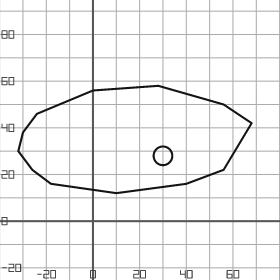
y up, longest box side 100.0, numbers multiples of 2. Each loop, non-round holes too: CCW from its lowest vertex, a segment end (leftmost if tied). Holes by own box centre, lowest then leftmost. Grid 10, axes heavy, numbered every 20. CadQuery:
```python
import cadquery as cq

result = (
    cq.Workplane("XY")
    .moveTo(10.0, 12.0)
    .lineTo(40.0, 16.0)
    .lineTo(56.0, 22.0)
    .lineTo(68.0, 42.0)
    .lineTo(56.0, 50.0)
    .lineTo(28.0, 58.0)
    .lineTo(0.0, 56.0)
    .lineTo(-24.0, 46.0)
    .lineTo(-30.0, 38.0)
    .lineTo(-32.0, 30.0)
    .lineTo(-26.0, 22.0)
    .lineTo(-18.0, 16.0)
    .close()
    .moveTo(30.0, 28.0)
    .circle(4.0)
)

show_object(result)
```